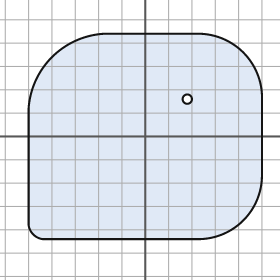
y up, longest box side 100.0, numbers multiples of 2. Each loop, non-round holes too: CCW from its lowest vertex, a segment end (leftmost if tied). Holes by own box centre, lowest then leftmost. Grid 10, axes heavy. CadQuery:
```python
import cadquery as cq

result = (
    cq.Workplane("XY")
    .moveTo(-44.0, -44.0)
    .lineTo(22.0, -44.0)
    .threePointArc((42.0, -36.0), (50.0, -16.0))
    .lineTo(50.0, 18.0)
    .threePointArc((42.0, 36.0), (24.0, 44.0))
    .lineTo(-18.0, 44.0)
    .threePointArc((-40.0, 34.0), (-50.0, 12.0))
    .lineTo(-50.0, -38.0)
    .threePointArc((-48.0, -42.0), (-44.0, -44.0))
    .close()
    .moveTo(18.0, 16.0)
    .circle(2.0)
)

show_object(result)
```